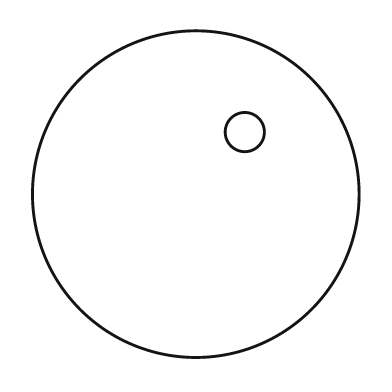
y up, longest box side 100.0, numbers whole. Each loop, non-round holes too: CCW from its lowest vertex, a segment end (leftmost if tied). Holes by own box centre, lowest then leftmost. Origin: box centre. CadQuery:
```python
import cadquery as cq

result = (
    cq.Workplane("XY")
    .moveTo(0.0, 0.0)
    .circle(50.0)
    .moveTo(15.0, 19.0)
    .circle(6.0)
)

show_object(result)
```